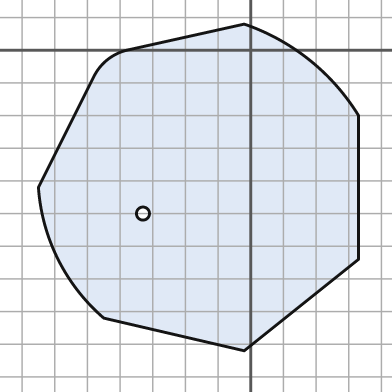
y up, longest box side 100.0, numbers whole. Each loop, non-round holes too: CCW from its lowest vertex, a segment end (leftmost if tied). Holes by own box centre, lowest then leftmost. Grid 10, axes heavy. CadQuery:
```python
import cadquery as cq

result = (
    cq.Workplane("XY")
    .moveTo(-2.0, -92.0)
    .lineTo(33.0, -64.0)
    .lineTo(33.0, -20.0)
    .threePointArc((18.0, -3.0), (-2.0, 8.0))
    .lineTo(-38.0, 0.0)
    .threePointArc((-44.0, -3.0), (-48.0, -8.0))
    .lineTo(-65.0, -42.0)
    .threePointArc((-59.0, -64.0), (-45.0, -82.0))
    .close()
    .moveTo(-33.0, -50.0)
    .circle(2.0)
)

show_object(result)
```